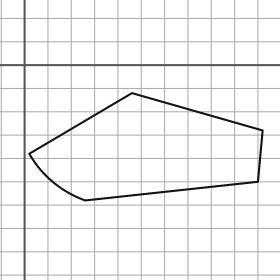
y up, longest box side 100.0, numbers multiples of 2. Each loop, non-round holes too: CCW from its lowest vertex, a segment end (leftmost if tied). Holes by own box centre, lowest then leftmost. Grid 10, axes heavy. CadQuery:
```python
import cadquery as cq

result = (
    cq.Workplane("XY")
    .moveTo(26.0, -58.0)
    .lineTo(100.0, -50.0)
    .lineTo(102.0, -28.0)
    .lineTo(46.0, -12.0)
    .lineTo(2.0, -38.0)
    .threePointArc((12.0, -50.0), (26.0, -58.0))
    .close()
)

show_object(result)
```